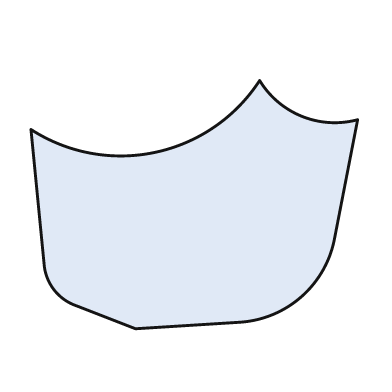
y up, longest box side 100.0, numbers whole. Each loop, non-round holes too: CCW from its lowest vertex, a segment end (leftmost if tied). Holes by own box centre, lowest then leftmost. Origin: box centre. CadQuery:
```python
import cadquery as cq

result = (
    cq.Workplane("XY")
    .moveTo(-18.0, -38.0)
    .lineTo(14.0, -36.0)
    .threePointArc((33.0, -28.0), (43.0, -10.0))
    .lineTo(50.0, 26.0)
    .threePointArc((33.0, 27.0), (20.0, 38.0))
    .threePointArc((-12.0, 16.0), (-50.0, 23.0))
    .lineTo(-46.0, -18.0)
    .threePointArc((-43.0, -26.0), (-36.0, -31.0))
    .close()
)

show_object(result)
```